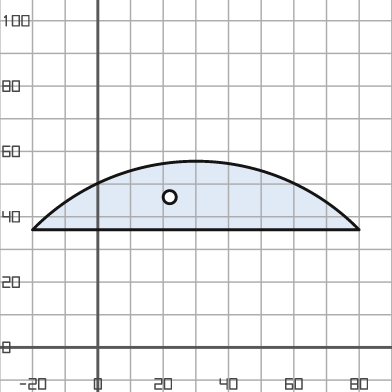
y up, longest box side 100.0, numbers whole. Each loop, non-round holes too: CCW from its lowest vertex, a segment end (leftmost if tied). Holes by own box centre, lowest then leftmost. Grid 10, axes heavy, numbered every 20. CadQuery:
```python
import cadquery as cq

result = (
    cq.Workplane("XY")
    .moveTo(-20.0, 36.0)
    .lineTo(80.0, 36.0)
    .threePointArc((30.0, 57.0), (-20.0, 36.0))
    .close()
    .moveTo(22.0, 46.0)
    .circle(2.0)
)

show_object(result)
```